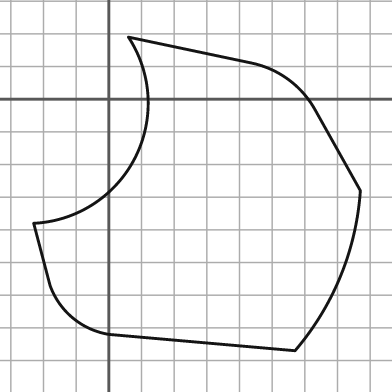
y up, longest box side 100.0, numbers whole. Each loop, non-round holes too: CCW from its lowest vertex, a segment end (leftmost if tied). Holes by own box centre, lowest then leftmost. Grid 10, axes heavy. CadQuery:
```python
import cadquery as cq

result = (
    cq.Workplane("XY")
    .moveTo(57.0, -77.0)
    .threePointArc((71.0, -54.0), (77.0, -28.0))
    .lineTo(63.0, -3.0)
    .threePointArc((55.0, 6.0), (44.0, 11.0))
    .lineTo(6.0, 19.0)
    .threePointArc((8.0, -18.0), (-23.0, -38.0))
    .lineTo(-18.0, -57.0)
    .threePointArc((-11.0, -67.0), (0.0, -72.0))
    .close()
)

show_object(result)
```